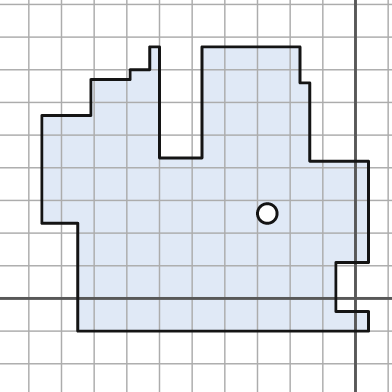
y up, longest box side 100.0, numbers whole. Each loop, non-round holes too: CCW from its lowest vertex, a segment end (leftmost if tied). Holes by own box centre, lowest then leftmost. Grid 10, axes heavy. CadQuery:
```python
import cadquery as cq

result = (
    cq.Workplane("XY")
    .moveTo(-85.0, -10.0)
    .lineTo(4.0, -10.0)
    .lineTo(4.0, -4.0)
    .lineTo(-6.0, -4.0)
    .lineTo(-6.0, 11.0)
    .lineTo(4.0, 11.0)
    .lineTo(4.0, 42.0)
    .lineTo(-14.0, 42.0)
    .lineTo(-14.0, 66.0)
    .lineTo(-17.0, 66.0)
    .lineTo(-17.0, 77.0)
    .lineTo(-47.0, 77.0)
    .lineTo(-47.0, 43.0)
    .lineTo(-60.0, 43.0)
    .lineTo(-60.0, 77.0)
    .lineTo(-63.0, 77.0)
    .lineTo(-63.0, 70.0)
    .lineTo(-69.0, 70.0)
    .lineTo(-69.0, 67.0)
    .lineTo(-81.0, 67.0)
    .lineTo(-81.0, 56.0)
    .lineTo(-96.0, 56.0)
    .lineTo(-96.0, 23.0)
    .lineTo(-85.0, 23.0)
    .close()
    .moveTo(-27.0, 26.0)
    .circle(3.0)
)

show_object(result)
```